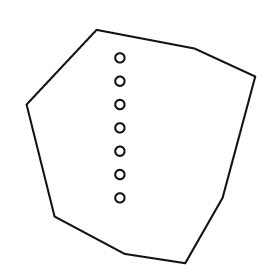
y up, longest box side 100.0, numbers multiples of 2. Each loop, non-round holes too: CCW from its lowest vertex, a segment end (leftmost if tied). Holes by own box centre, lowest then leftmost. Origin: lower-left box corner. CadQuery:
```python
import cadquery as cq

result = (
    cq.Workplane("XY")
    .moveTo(68.0, 0.0)
    .lineTo(84.0, 28.0)
    .lineTo(98.0, 80.0)
    .lineTo(72.0, 92.0)
    .lineTo(30.0, 100.0)
    .lineTo(0.0, 68.0)
    .lineTo(12.0, 20.0)
    .lineTo(42.0, 4.0)
    .close()
    .moveTo(40.0, 28.0)
    .circle(2.0)
    .moveTo(40.0, 38.0)
    .circle(2.0)
    .moveTo(40.0, 48.0)
    .circle(2.0)
    .moveTo(40.0, 58.0)
    .circle(2.0)
    .moveTo(40.0, 68.0)
    .circle(2.0)
    .moveTo(40.0, 78.0)
    .circle(2.0)
    .moveTo(40.0, 88.0)
    .circle(2.0)
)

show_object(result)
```